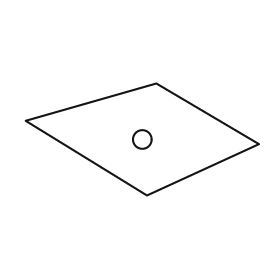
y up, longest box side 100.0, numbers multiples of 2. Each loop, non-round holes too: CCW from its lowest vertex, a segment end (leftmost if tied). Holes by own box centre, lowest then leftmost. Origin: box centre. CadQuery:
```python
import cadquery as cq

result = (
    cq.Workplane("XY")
    .moveTo(2.0, -24.0)
    .lineTo(50.0, -2.0)
    .lineTo(6.0, 24.0)
    .lineTo(-50.0, 8.0)
    .close()
    .moveTo(0.0, 0.0)
    .circle(4.0)
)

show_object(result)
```